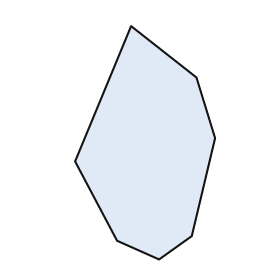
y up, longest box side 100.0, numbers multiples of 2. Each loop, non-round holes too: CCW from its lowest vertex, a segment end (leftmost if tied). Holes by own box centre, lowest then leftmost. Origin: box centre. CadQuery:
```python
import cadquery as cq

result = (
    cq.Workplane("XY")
    .moveTo(6.0, -50.0)
    .lineTo(20.0, -40.0)
    .lineTo(30.0, 2.0)
    .lineTo(22.0, 28.0)
    .lineTo(-6.0, 50.0)
    .lineTo(-30.0, -8.0)
    .lineTo(-12.0, -42.0)
    .close()
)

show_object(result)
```